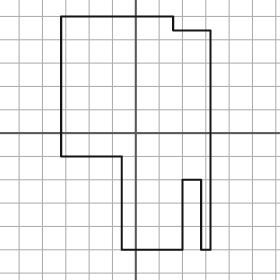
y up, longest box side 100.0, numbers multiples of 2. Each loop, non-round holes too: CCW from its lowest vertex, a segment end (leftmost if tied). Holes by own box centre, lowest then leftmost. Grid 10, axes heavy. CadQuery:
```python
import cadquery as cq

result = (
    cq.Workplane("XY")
    .moveTo(-6.0, -50.0)
    .lineTo(20.0, -50.0)
    .lineTo(20.0, -20.0)
    .lineTo(28.0, -20.0)
    .lineTo(28.0, -50.0)
    .lineTo(32.0, -50.0)
    .lineTo(32.0, 44.0)
    .lineTo(16.0, 44.0)
    .lineTo(16.0, 50.0)
    .lineTo(-32.0, 50.0)
    .lineTo(-32.0, -10.0)
    .lineTo(-6.0, -10.0)
    .close()
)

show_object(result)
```